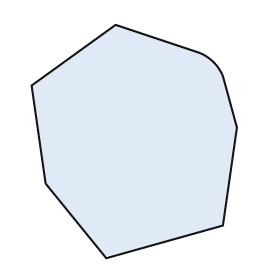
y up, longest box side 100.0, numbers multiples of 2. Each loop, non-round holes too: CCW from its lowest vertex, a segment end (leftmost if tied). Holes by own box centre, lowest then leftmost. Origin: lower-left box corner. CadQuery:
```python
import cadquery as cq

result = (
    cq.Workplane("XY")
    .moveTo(32.0, 0.0)
    .lineTo(82.0, 14.0)
    .lineTo(88.0, 56.0)
    .lineTo(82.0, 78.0)
    .threePointArc((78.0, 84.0), (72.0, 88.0))
    .lineTo(36.0, 100.0)
    .lineTo(0.0, 74.0)
    .lineTo(6.0, 32.0)
    .close()
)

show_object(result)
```